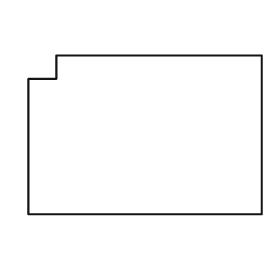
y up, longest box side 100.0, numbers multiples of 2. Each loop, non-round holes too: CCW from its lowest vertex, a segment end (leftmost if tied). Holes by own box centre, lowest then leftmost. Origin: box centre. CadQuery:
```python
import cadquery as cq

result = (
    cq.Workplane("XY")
    .moveTo(-50.0, -34.0)
    .lineTo(50.0, -34.0)
    .lineTo(50.0, 34.0)
    .lineTo(-38.0, 34.0)
    .lineTo(-38.0, 24.0)
    .lineTo(-50.0, 24.0)
    .close()
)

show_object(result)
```